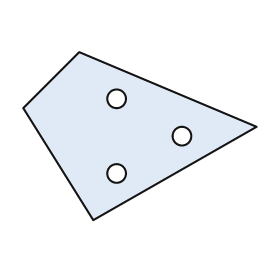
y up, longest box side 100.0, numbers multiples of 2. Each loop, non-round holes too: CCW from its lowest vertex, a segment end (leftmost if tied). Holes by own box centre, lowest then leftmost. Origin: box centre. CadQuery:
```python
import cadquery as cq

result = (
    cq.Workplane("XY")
    .moveTo(-20.0, -36.0)
    .lineTo(50.0, 4.0)
    .lineTo(-26.0, 36.0)
    .lineTo(-50.0, 12.0)
    .close()
    .moveTo(-10.0, -16.0)
    .circle(4.0)
    .moveTo(18.0, 0.0)
    .circle(4.0)
    .moveTo(-10.0, 16.0)
    .circle(4.0)
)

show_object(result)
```